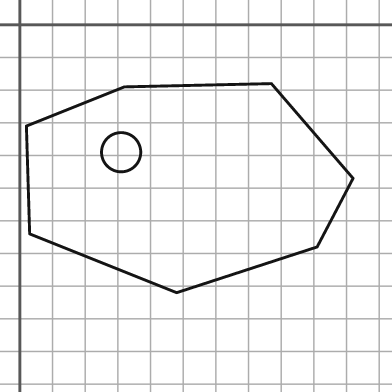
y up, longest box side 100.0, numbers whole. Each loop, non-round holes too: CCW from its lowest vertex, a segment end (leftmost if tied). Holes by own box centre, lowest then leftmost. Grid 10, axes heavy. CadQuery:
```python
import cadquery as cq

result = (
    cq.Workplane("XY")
    .moveTo(48.0, -82.0)
    .lineTo(91.0, -68.0)
    .lineTo(102.0, -47.0)
    .lineTo(77.0, -18.0)
    .lineTo(32.0, -19.0)
    .lineTo(2.0, -31.0)
    .lineTo(3.0, -64.0)
    .close()
    .moveTo(31.0, -39.0)
    .circle(6.0)
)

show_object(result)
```